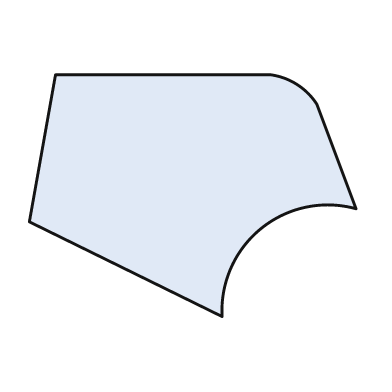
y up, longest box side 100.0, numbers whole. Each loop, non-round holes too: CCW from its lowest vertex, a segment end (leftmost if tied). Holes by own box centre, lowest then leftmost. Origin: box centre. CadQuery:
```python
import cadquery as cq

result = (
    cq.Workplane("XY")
    .moveTo(9.0, -37.0)
    .threePointArc((21.0, -10.0), (50.0, -4.0))
    .lineTo(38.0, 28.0)
    .threePointArc((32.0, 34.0), (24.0, 37.0))
    .lineTo(-42.0, 37.0)
    .lineTo(-50.0, -8.0)
    .close()
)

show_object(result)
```